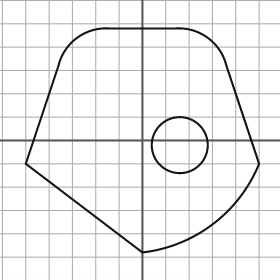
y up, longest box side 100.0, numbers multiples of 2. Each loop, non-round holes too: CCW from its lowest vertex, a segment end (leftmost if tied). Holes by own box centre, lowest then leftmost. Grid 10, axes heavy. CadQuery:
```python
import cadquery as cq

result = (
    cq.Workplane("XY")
    .moveTo(0.0, -48.0)
    .threePointArc((30.0, -36.0), (50.0, -10.0))
    .lineTo(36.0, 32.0)
    .threePointArc((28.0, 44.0), (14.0, 48.0))
    .lineTo(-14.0, 48.0)
    .threePointArc((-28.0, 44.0), (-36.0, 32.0))
    .lineTo(-50.0, -10.0)
    .close()
    .moveTo(16.0, -2.0)
    .circle(12.0)
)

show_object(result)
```